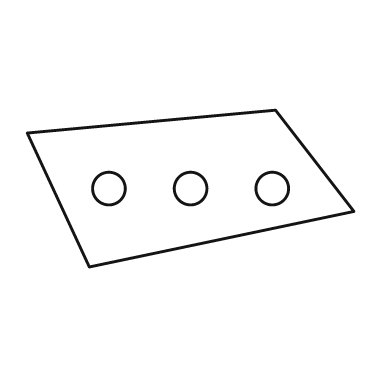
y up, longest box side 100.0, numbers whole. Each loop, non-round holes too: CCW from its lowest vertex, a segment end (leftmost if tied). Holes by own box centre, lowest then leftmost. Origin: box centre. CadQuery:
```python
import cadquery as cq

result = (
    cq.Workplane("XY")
    .moveTo(-31.0, -24.0)
    .lineTo(50.0, -7.0)
    .lineTo(26.0, 24.0)
    .lineTo(-50.0, 17.0)
    .close()
    .moveTo(-25.0, 0.0)
    .circle(5.0)
    .moveTo(0.0, 0.0)
    .circle(5.0)
    .moveTo(25.0, 0.0)
    .circle(5.0)
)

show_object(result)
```